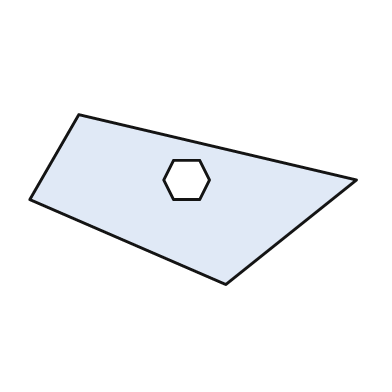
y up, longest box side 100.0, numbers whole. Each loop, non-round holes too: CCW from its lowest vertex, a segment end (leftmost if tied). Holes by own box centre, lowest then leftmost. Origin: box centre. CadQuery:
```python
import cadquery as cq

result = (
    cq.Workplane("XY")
    .moveTo(10.0, -26.0)
    .lineTo(50.0, 6.0)
    .lineTo(-35.0, 26.0)
    .lineTo(-50.0, 0.0)
    .close()
    .moveTo(-6.0, 0.0)
    .lineTo(2.0, 0.0)
    .lineTo(5.0, 6.0)
    .lineTo(2.0, 12.0)
    .lineTo(-6.0, 12.0)
    .lineTo(-9.0, 6.0)
    .close()
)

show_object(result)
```